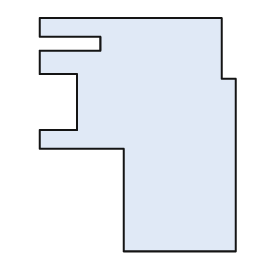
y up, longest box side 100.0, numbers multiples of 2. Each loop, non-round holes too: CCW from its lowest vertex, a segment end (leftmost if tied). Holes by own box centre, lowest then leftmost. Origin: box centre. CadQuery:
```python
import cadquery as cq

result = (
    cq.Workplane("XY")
    .moveTo(-6.0, -50.0)
    .lineTo(42.0, -50.0)
    .lineTo(42.0, 24.0)
    .lineTo(36.0, 24.0)
    .lineTo(36.0, 50.0)
    .lineTo(-42.0, 50.0)
    .lineTo(-42.0, 42.0)
    .lineTo(-16.0, 42.0)
    .lineTo(-16.0, 36.0)
    .lineTo(-42.0, 36.0)
    .lineTo(-42.0, 26.0)
    .lineTo(-26.0, 26.0)
    .lineTo(-26.0, 2.0)
    .lineTo(-42.0, 2.0)
    .lineTo(-42.0, -6.0)
    .lineTo(-6.0, -6.0)
    .close()
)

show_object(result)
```